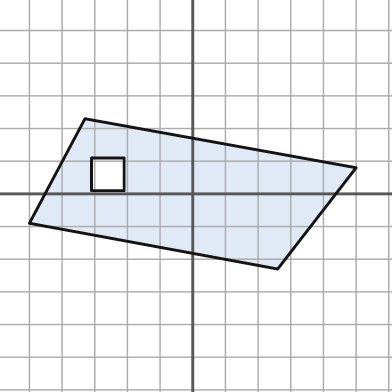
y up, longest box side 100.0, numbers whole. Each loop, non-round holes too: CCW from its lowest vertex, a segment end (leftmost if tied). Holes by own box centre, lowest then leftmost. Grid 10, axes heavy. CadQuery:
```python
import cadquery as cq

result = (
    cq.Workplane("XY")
    .moveTo(26.0, -23.0)
    .lineTo(50.0, 8.0)
    .lineTo(-33.0, 23.0)
    .lineTo(-50.0, -9.0)
    .close()
    .moveTo(-31.0, 1.0)
    .lineTo(-21.0, 1.0)
    .lineTo(-21.0, 11.0)
    .lineTo(-31.0, 11.0)
    .close()
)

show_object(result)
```